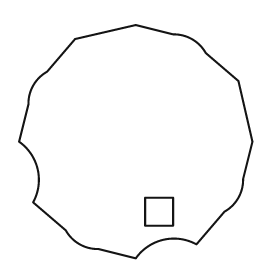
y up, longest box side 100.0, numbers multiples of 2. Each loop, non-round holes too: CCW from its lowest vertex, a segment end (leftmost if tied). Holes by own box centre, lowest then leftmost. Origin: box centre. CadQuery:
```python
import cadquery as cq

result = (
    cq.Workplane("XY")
    .moveTo(0.0, -50.0)
    .threePointArc((12.0, -42.0), (26.0, -44.0))
    .lineTo(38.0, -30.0)
    .threePointArc((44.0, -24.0), (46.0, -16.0))
    .lineTo(50.0, 0.0)
    .lineTo(44.0, 26.0)
    .lineTo(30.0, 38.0)
    .threePointArc((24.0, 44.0), (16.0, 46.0))
    .lineTo(0.0, 50.0)
    .lineTo(-26.0, 44.0)
    .lineTo(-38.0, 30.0)
    .threePointArc((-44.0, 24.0), (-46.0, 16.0))
    .lineTo(-50.0, 0.0)
    .threePointArc((-42.0, -12.0), (-44.0, -26.0))
    .lineTo(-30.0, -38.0)
    .threePointArc((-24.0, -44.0), (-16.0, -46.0))
    .close()
    .moveTo(4.0, -36.0)
    .lineTo(16.0, -36.0)
    .lineTo(16.0, -24.0)
    .lineTo(4.0, -24.0)
    .close()
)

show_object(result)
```